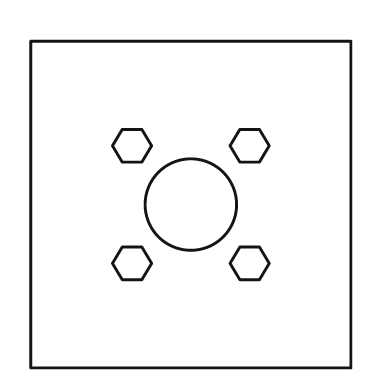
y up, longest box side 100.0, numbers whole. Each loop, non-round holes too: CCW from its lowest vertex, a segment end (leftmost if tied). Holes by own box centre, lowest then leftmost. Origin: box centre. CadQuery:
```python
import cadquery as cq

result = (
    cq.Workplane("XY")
    .moveTo(-49.0, -50.0)
    .lineTo(49.0, -50.0)
    .lineTo(49.0, 50.0)
    .lineTo(-49.0, 50.0)
    .close()
    .moveTo(-21.0, -23.0)
    .lineTo(-15.0, -23.0)
    .lineTo(-12.0, -18.0)
    .lineTo(-15.0, -13.0)
    .lineTo(-21.0, -13.0)
    .lineTo(-24.0, -18.0)
    .close()
    .moveTo(15.0, -23.0)
    .lineTo(21.0, -23.0)
    .lineTo(24.0, -18.0)
    .lineTo(21.0, -13.0)
    .lineTo(15.0, -13.0)
    .lineTo(12.0, -18.0)
    .close()
    .moveTo(0.0, 0.0)
    .circle(14.0)
    .moveTo(-21.0, 13.0)
    .lineTo(-15.0, 13.0)
    .lineTo(-12.0, 18.0)
    .lineTo(-15.0, 23.0)
    .lineTo(-21.0, 23.0)
    .lineTo(-24.0, 18.0)
    .close()
    .moveTo(15.0, 13.0)
    .lineTo(21.0, 13.0)
    .lineTo(24.0, 18.0)
    .lineTo(21.0, 23.0)
    .lineTo(15.0, 23.0)
    .lineTo(12.0, 18.0)
    .close()
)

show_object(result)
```